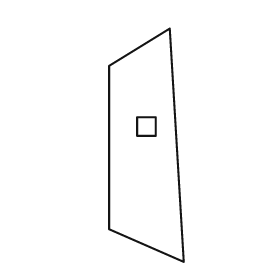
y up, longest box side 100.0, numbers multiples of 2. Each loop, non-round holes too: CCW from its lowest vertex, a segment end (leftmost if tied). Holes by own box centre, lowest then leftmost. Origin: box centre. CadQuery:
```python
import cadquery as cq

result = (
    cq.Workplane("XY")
    .moveTo(16.0, -50.0)
    .lineTo(10.0, 50.0)
    .lineTo(-16.0, 34.0)
    .lineTo(-16.0, -36.0)
    .close()
    .moveTo(-4.0, 4.0)
    .lineTo(4.0, 4.0)
    .lineTo(4.0, 12.0)
    .lineTo(-4.0, 12.0)
    .close()
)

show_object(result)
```